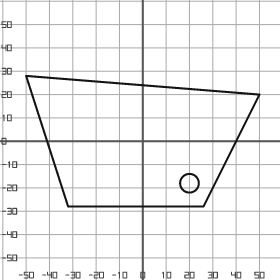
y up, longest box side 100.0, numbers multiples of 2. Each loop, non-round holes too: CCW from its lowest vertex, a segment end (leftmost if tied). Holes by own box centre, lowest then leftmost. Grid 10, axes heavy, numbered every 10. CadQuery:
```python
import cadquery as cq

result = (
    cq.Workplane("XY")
    .moveTo(-32.0, -28.0)
    .lineTo(26.0, -28.0)
    .lineTo(50.0, 20.0)
    .lineTo(-50.0, 28.0)
    .close()
    .moveTo(20.0, -18.0)
    .circle(4.0)
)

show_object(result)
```